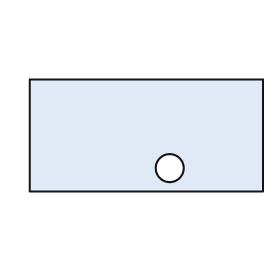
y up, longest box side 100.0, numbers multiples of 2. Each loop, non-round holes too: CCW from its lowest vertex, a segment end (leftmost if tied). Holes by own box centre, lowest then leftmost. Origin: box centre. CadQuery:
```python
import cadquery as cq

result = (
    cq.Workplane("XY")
    .moveTo(-50.0, -24.0)
    .lineTo(50.0, -24.0)
    .lineTo(50.0, 24.0)
    .lineTo(-50.0, 24.0)
    .close()
    .moveTo(10.0, -14.0)
    .circle(6.0)
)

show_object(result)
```